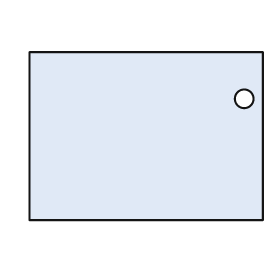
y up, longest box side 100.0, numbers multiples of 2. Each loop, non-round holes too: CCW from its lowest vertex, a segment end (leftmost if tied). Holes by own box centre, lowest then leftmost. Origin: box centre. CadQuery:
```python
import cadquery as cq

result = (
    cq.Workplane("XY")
    .moveTo(-50.0, -36.0)
    .lineTo(50.0, -36.0)
    .lineTo(50.0, 36.0)
    .lineTo(-50.0, 36.0)
    .close()
    .moveTo(42.0, 16.0)
    .circle(4.0)
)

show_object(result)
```